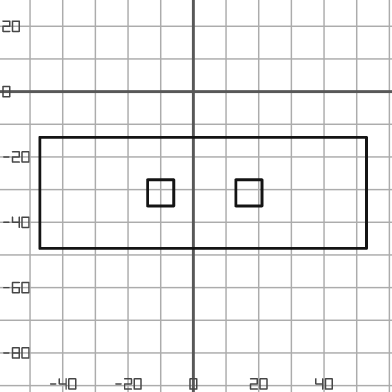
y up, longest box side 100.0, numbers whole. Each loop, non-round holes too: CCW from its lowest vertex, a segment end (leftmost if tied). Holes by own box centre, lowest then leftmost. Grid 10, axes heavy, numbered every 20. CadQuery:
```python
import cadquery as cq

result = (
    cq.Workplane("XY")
    .moveTo(-47.0, -48.0)
    .lineTo(53.0, -48.0)
    .lineTo(53.0, -14.0)
    .lineTo(-47.0, -14.0)
    .close()
    .moveTo(-14.0, -35.0)
    .lineTo(-6.0, -35.0)
    .lineTo(-6.0, -27.0)
    .lineTo(-14.0, -27.0)
    .close()
    .moveTo(13.0, -35.0)
    .lineTo(21.0, -35.0)
    .lineTo(21.0, -27.0)
    .lineTo(13.0, -27.0)
    .close()
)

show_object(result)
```